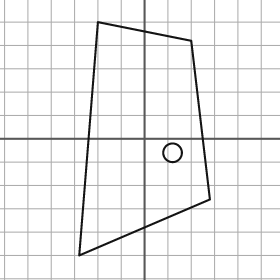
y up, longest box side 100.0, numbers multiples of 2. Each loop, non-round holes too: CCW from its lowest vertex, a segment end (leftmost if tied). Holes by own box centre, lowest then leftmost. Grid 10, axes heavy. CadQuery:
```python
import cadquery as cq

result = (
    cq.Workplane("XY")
    .moveTo(-28.0, -50.0)
    .lineTo(28.0, -26.0)
    .lineTo(20.0, 42.0)
    .lineTo(-20.0, 50.0)
    .close()
    .moveTo(12.0, -6.0)
    .circle(4.0)
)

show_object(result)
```